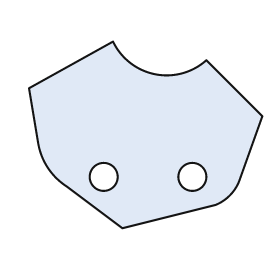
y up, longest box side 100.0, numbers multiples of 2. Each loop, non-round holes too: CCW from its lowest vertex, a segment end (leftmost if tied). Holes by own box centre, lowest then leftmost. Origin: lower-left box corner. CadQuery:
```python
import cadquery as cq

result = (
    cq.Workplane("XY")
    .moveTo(40.0, 0.0)
    .lineTo(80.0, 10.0)
    .threePointArc((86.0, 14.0), (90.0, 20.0))
    .lineTo(100.0, 48.0)
    .lineTo(76.0, 72.0)
    .threePointArc((54.0, 66.0), (36.0, 80.0))
    .lineTo(0.0, 60.0)
    .lineTo(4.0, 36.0)
    .threePointArc((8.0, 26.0), (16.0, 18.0))
    .close()
    .moveTo(32.0, 22.0)
    .circle(6.0)
    .moveTo(70.0, 22.0)
    .circle(6.0)
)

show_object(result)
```